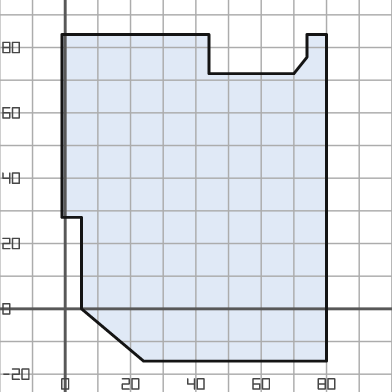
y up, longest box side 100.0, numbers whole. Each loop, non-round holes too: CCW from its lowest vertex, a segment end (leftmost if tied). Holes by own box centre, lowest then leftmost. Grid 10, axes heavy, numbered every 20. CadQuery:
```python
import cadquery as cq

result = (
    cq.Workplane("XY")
    .moveTo(24.0, -16.0)
    .lineTo(80.0, -16.0)
    .lineTo(80.0, 84.0)
    .lineTo(74.0, 84.0)
    .lineTo(74.0, 77.0)
    .lineTo(70.0, 72.0)
    .lineTo(44.0, 72.0)
    .lineTo(44.0, 84.0)
    .lineTo(-1.0, 84.0)
    .lineTo(-1.0, 28.0)
    .lineTo(5.0, 28.0)
    .lineTo(5.0, 0.0)
    .close()
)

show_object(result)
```